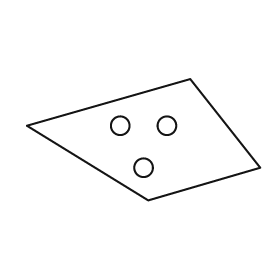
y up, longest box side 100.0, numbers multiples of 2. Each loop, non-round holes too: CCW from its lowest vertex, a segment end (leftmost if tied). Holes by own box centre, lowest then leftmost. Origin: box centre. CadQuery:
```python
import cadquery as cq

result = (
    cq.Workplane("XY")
    .moveTo(2.0, -26.0)
    .lineTo(50.0, -12.0)
    .lineTo(20.0, 26.0)
    .lineTo(-50.0, 6.0)
    .close()
    .moveTo(0.0, -12.0)
    .circle(4.0)
    .moveTo(-10.0, 6.0)
    .circle(4.0)
    .moveTo(10.0, 6.0)
    .circle(4.0)
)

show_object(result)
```